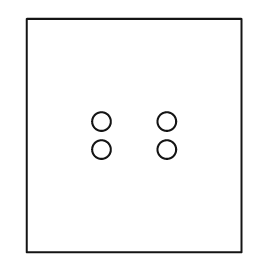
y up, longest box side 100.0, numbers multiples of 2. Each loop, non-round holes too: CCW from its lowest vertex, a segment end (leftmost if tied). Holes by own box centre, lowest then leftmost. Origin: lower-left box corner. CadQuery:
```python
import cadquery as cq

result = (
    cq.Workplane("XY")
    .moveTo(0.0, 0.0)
    .lineTo(92.0, 0.0)
    .lineTo(92.0, 100.0)
    .lineTo(0.0, 100.0)
    .close()
    .moveTo(32.0, 44.0)
    .circle(4.0)
    .moveTo(60.0, 44.0)
    .circle(4.0)
    .moveTo(32.0, 56.0)
    .circle(4.0)
    .moveTo(60.0, 56.0)
    .circle(4.0)
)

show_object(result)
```